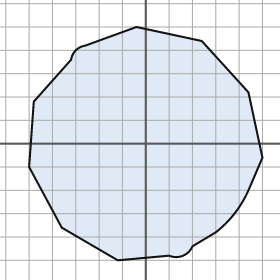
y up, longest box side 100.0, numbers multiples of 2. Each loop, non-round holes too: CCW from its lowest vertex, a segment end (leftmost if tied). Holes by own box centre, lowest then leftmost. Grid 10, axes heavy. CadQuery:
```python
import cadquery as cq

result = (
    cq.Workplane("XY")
    .moveTo(-12.0, -50.0)
    .lineTo(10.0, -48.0)
    .threePointArc((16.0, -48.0), (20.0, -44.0))
    .lineTo(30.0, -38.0)
    .threePointArc((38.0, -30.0), (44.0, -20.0))
    .lineTo(50.0, -6.0)
    .lineTo(44.0, 22.0)
    .lineTo(24.0, 44.0)
    .lineTo(-4.0, 50.0)
    .lineTo(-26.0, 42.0)
    .threePointArc((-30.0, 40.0), (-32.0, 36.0))
    .lineTo(-48.0, 18.0)
    .lineTo(-50.0, -10.0)
    .lineTo(-36.0, -36.0)
    .close()
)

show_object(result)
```